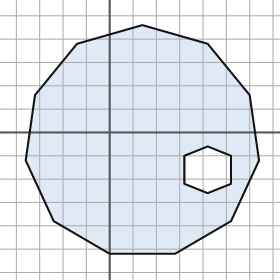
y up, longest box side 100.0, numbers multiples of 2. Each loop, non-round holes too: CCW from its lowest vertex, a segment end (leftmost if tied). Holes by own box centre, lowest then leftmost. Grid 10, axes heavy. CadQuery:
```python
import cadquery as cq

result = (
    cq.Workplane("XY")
    .moveTo(0.0, -52.0)
    .lineTo(28.0, -52.0)
    .lineTo(52.0, -38.0)
    .lineTo(64.0, -12.0)
    .lineTo(60.0, 16.0)
    .lineTo(42.0, 38.0)
    .lineTo(14.0, 46.0)
    .lineTo(-14.0, 38.0)
    .lineTo(-32.0, 16.0)
    .lineTo(-36.0, -12.0)
    .lineTo(-24.0, -38.0)
    .close()
    .moveTo(42.0, -26.0)
    .lineTo(52.0, -22.0)
    .lineTo(52.0, -10.0)
    .lineTo(42.0, -6.0)
    .lineTo(32.0, -10.0)
    .lineTo(32.0, -22.0)
    .close()
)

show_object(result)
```